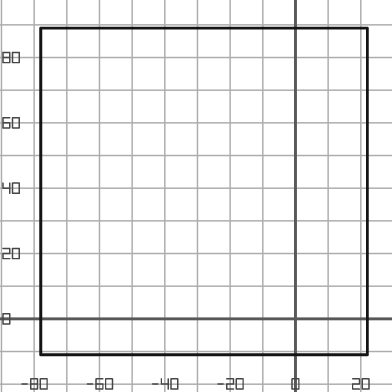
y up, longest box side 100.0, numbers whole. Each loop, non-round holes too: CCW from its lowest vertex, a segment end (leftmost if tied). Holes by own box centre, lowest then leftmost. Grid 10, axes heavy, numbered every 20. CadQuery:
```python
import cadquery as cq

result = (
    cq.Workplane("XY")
    .moveTo(-78.0, -11.0)
    .lineTo(22.0, -11.0)
    .lineTo(22.0, 89.0)
    .lineTo(-78.0, 89.0)
    .close()
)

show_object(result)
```